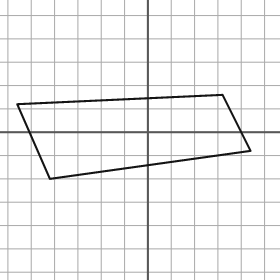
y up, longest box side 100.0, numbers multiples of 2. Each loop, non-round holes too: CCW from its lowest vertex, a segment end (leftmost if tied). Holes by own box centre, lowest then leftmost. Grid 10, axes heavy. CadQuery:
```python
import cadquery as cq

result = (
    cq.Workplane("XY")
    .moveTo(-42.0, -20.0)
    .lineTo(44.0, -8.0)
    .lineTo(32.0, 16.0)
    .lineTo(-56.0, 12.0)
    .close()
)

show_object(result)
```